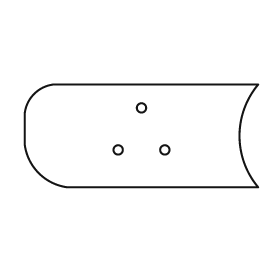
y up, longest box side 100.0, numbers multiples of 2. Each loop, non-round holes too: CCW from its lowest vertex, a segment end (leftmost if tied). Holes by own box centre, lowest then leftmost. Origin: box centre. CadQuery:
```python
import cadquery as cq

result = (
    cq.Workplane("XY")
    .moveTo(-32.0, -22.0)
    .lineTo(50.0, -22.0)
    .threePointArc((42.0, 0.0), (50.0, 22.0))
    .lineTo(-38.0, 22.0)
    .threePointArc((-46.0, 18.0), (-50.0, 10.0))
    .lineTo(-50.0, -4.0)
    .threePointArc((-44.0, -16.0), (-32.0, -22.0))
    .close()
    .moveTo(-10.0, -6.0)
    .circle(2.0)
    .moveTo(10.0, -6.0)
    .circle(2.0)
    .moveTo(0.0, 12.0)
    .circle(2.0)
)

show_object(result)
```